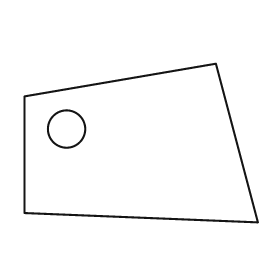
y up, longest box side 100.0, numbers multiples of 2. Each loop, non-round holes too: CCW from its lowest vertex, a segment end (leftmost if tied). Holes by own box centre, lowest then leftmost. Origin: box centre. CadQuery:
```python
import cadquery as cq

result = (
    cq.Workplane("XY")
    .moveTo(50.0, -34.0)
    .lineTo(32.0, 34.0)
    .lineTo(-50.0, 20.0)
    .lineTo(-50.0, -30.0)
    .close()
    .moveTo(-32.0, 6.0)
    .circle(8.0)
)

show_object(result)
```